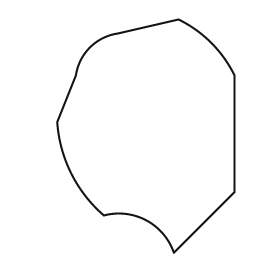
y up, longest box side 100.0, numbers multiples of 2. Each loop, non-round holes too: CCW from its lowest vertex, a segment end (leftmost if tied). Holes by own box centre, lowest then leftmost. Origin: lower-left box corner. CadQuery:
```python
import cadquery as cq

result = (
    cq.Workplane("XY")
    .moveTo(50.0, 0.0)
    .lineTo(76.0, 26.0)
    .lineTo(76.0, 76.0)
    .threePointArc((66.0, 90.0), (52.0, 100.0))
    .lineTo(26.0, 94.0)
    .threePointArc((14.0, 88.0), (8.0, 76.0))
    .lineTo(0.0, 56.0)
    .threePointArc((6.0, 34.0), (20.0, 16.0))
    .threePointArc((38.0, 14.0), (50.0, 0.0))
    .close()
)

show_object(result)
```